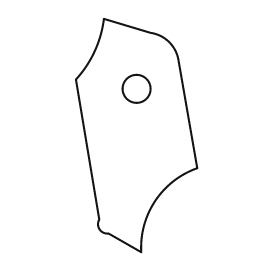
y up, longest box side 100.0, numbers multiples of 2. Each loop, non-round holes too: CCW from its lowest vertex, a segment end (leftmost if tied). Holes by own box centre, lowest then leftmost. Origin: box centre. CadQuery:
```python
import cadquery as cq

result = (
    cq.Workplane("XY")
    .moveTo(2.0, -50.0)
    .threePointArc((8.0, -28.0), (26.0, -14.0))
    .lineTo(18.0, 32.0)
    .threePointArc((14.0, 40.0), (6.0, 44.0))
    .lineTo(-14.0, 50.0)
    .threePointArc((-18.0, 36.0), (-26.0, 24.0))
    .lineTo(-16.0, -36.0)
    .threePointArc((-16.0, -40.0), (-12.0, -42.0))
    .close()
    .moveTo(0.0, 20.0)
    .circle(6.0)
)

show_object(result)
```